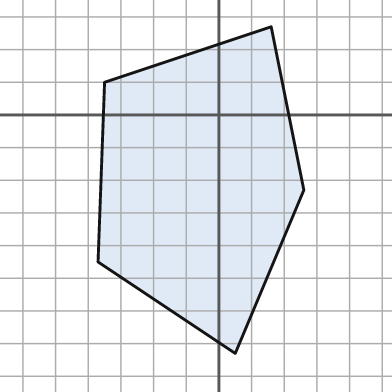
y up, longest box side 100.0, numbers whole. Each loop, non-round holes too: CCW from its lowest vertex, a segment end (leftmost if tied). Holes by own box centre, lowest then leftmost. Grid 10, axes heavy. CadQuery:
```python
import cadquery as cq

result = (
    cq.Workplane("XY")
    .moveTo(5.0, -73.0)
    .lineTo(26.0, -23.0)
    .lineTo(16.0, 27.0)
    .lineTo(-35.0, 10.0)
    .lineTo(-37.0, -45.0)
    .close()
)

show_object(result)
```